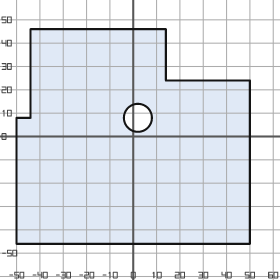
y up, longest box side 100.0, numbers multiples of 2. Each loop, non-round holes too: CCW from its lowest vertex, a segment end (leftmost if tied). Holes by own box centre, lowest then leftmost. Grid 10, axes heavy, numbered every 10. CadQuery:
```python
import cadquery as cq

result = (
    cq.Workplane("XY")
    .moveTo(-50.0, -46.0)
    .lineTo(50.0, -46.0)
    .lineTo(50.0, 24.0)
    .lineTo(14.0, 24.0)
    .lineTo(14.0, 46.0)
    .lineTo(-44.0, 46.0)
    .lineTo(-44.0, 8.0)
    .lineTo(-50.0, 8.0)
    .close()
    .moveTo(2.0, 8.0)
    .circle(6.0)
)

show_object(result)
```